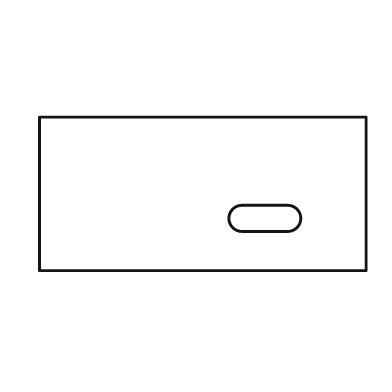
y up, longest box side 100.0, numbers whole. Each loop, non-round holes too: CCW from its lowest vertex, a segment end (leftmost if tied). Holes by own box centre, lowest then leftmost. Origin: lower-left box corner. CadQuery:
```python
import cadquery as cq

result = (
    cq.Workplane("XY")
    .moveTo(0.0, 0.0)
    .lineTo(100.0, 0.0)
    .lineTo(100.0, 47.0)
    .lineTo(0.0, 47.0)
    .close()
    .moveTo(62.0, 12.0)
    .lineTo(76.0, 12.0)
    .threePointArc((80.0, 16.0), (76.0, 20.0))
    .lineTo(62.0, 20.0)
    .threePointArc((58.0, 16.0), (62.0, 12.0))
    .close()
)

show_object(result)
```